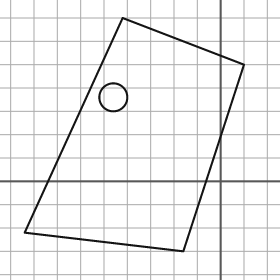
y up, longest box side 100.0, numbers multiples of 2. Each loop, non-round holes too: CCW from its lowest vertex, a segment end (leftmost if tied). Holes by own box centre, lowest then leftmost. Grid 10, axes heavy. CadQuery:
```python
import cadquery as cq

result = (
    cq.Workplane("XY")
    .moveTo(-16.0, -30.0)
    .lineTo(10.0, 50.0)
    .lineTo(-42.0, 70.0)
    .lineTo(-84.0, -22.0)
    .close()
    .moveTo(-46.0, 36.0)
    .circle(6.0)
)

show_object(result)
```